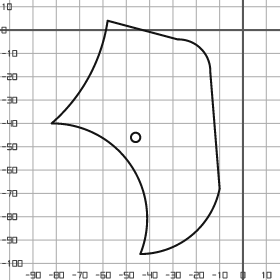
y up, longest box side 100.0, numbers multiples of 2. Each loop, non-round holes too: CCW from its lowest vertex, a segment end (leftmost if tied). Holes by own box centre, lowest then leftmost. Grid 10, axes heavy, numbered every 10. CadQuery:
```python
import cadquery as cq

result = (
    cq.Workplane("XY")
    .moveTo(-44.0, -96.0)
    .threePointArc((-22.0, -88.0), (-10.0, -68.0))
    .lineTo(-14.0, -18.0)
    .threePointArc((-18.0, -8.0), (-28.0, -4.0))
    .lineTo(-58.0, 4.0)
    .threePointArc((-66.0, -20.0), (-82.0, -40.0))
    .threePointArc((-48.0, -58.0), (-44.0, -96.0))
    .close()
    .moveTo(-46.0, -46.0)
    .circle(2.0)
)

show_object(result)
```